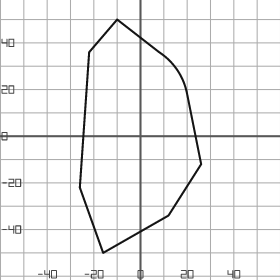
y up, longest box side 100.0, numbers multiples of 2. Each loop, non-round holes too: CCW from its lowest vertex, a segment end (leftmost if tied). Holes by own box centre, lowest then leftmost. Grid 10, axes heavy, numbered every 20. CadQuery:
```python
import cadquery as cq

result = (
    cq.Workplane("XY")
    .moveTo(-16.0, -50.0)
    .lineTo(12.0, -34.0)
    .lineTo(26.0, -12.0)
    .lineTo(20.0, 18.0)
    .threePointArc((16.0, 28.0), (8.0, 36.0))
    .lineTo(-10.0, 50.0)
    .lineTo(-22.0, 36.0)
    .lineTo(-26.0, -22.0)
    .close()
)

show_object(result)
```